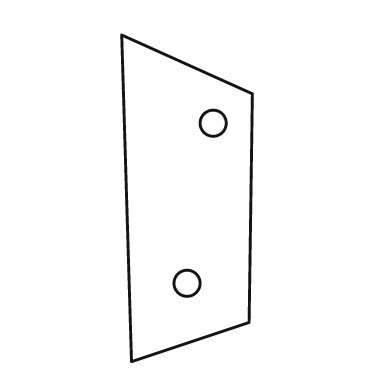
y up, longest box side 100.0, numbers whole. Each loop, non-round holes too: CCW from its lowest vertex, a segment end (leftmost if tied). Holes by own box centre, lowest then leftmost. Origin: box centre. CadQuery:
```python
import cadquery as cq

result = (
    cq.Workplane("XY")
    .moveTo(-17.0, -50.0)
    .lineTo(19.0, -38.0)
    .lineTo(20.0, 32.0)
    .lineTo(-20.0, 50.0)
    .close()
    .moveTo(0.0, -26.0)
    .circle(4.0)
    .moveTo(8.0, 23.0)
    .circle(4.0)
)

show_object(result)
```